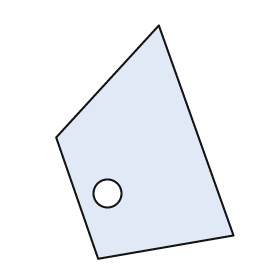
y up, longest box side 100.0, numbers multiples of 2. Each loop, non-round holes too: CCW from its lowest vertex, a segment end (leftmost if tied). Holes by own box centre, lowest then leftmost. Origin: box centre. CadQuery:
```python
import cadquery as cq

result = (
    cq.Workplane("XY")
    .moveTo(-20.0, -50.0)
    .lineTo(38.0, -40.0)
    .lineTo(6.0, 50.0)
    .lineTo(-38.0, 2.0)
    .close()
    .moveTo(-16.0, -22.0)
    .circle(6.0)
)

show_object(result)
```